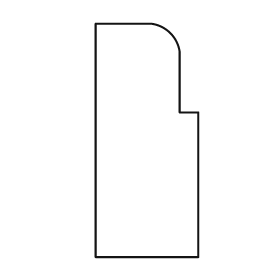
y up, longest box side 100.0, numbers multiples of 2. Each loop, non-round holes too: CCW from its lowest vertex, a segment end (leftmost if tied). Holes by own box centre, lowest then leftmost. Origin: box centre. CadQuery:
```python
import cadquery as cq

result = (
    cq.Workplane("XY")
    .moveTo(-22.0, -50.0)
    .lineTo(22.0, -50.0)
    .lineTo(22.0, 12.0)
    .lineTo(14.0, 12.0)
    .lineTo(14.0, 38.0)
    .threePointArc((10.0, 46.0), (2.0, 50.0))
    .lineTo(-22.0, 50.0)
    .close()
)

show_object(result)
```